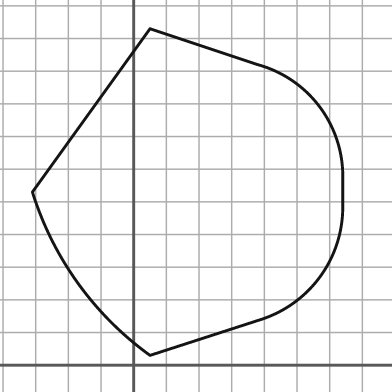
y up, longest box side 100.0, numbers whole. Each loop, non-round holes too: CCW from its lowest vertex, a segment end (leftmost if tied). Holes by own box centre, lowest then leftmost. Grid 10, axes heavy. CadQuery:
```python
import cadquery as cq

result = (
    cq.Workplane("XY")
    .moveTo(5.0, 3.0)
    .lineTo(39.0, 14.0)
    .threePointArc((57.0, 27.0), (64.0, 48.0))
    .lineTo(64.0, 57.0)
    .threePointArc((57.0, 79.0), (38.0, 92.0))
    .lineTo(5.0, 103.0)
    .lineTo(-31.0, 53.0)
    .threePointArc((-17.0, 25.0), (5.0, 3.0))
    .close()
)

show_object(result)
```